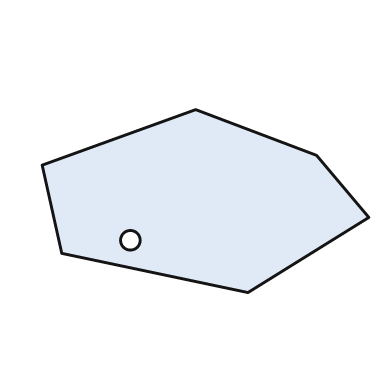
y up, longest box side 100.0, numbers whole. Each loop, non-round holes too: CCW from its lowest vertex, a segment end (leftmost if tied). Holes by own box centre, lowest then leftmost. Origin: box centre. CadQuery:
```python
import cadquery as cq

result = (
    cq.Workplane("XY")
    .moveTo(13.0, -28.0)
    .lineTo(50.0, -5.0)
    .lineTo(34.0, 14.0)
    .lineTo(-3.0, 28.0)
    .lineTo(-50.0, 11.0)
    .lineTo(-44.0, -16.0)
    .close()
    .moveTo(-23.0, -12.0)
    .circle(3.0)
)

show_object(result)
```